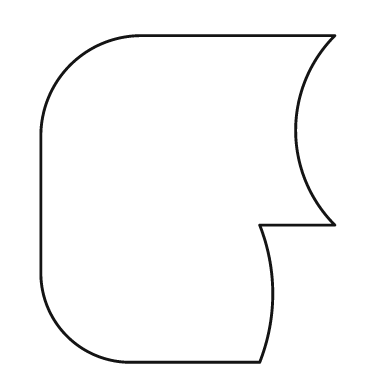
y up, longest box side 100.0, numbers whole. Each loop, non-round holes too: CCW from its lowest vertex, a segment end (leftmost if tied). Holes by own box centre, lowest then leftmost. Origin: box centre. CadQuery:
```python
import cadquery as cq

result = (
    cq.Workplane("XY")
    .moveTo(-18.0, -50.0)
    .lineTo(22.0, -50.0)
    .threePointArc((26.0, -29.0), (22.0, -8.0))
    .lineTo(45.0, -8.0)
    .threePointArc((33.0, 21.0), (45.0, 50.0))
    .lineTo(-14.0, 50.0)
    .threePointArc((-36.0, 41.0), (-45.0, 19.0))
    .lineTo(-45.0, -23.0)
    .threePointArc((-37.0, -42.0), (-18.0, -50.0))
    .close()
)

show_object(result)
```